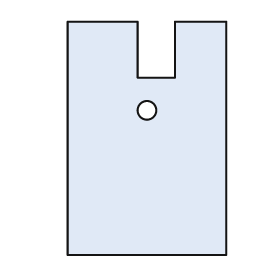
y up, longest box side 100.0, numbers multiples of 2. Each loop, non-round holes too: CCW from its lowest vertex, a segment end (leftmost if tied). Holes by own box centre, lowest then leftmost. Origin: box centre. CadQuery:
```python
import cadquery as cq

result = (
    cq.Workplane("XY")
    .moveTo(-34.0, -50.0)
    .lineTo(34.0, -50.0)
    .lineTo(34.0, 50.0)
    .lineTo(12.0, 50.0)
    .lineTo(12.0, 26.0)
    .lineTo(-4.0, 26.0)
    .lineTo(-4.0, 50.0)
    .lineTo(-34.0, 50.0)
    .close()
    .moveTo(0.0, 12.0)
    .circle(4.0)
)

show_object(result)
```